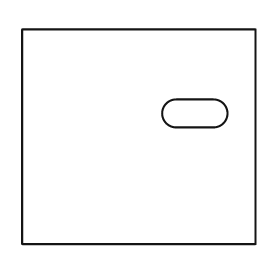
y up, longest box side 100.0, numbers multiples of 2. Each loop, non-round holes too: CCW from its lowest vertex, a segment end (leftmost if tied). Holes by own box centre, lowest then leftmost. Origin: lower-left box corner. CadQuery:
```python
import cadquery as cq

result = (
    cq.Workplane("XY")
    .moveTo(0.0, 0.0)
    .lineTo(100.0, 0.0)
    .lineTo(100.0, 92.0)
    .lineTo(0.0, 92.0)
    .close()
    .moveTo(66.0, 50.0)
    .lineTo(82.0, 50.0)
    .threePointArc((88.0, 56.0), (82.0, 62.0))
    .lineTo(66.0, 62.0)
    .threePointArc((60.0, 56.0), (66.0, 50.0))
    .close()
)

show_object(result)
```